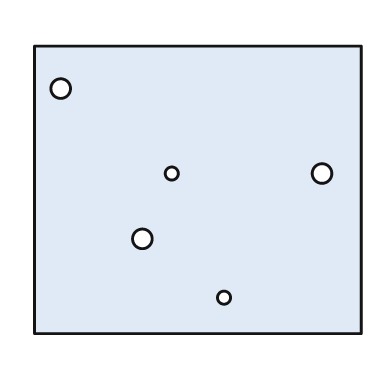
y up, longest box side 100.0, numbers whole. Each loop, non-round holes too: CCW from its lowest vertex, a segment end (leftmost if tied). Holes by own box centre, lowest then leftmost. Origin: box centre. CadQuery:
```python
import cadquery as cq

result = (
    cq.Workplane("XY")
    .moveTo(-50.0, -44.0)
    .lineTo(50.0, -44.0)
    .lineTo(50.0, 44.0)
    .lineTo(-50.0, 44.0)
    .close()
    .moveTo(8.0, -33.0)
    .circle(2.0)
    .moveTo(-17.0, -15.0)
    .circle(3.0)
    .moveTo(-8.0, 5.0)
    .circle(2.0)
    .moveTo(38.0, 5.0)
    .circle(3.0)
    .moveTo(-42.0, 31.0)
    .circle(3.0)
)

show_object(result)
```